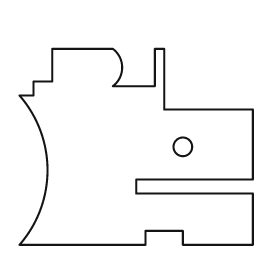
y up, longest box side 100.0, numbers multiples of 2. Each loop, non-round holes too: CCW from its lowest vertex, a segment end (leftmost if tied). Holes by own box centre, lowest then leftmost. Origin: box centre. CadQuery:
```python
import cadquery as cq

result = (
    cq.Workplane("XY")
    .moveTo(-50.0, -42.0)
    .lineTo(4.0, -42.0)
    .lineTo(4.0, -36.0)
    .lineTo(20.0, -36.0)
    .lineTo(20.0, -42.0)
    .lineTo(50.0, -42.0)
    .lineTo(50.0, -20.0)
    .lineTo(0.0, -20.0)
    .lineTo(0.0, -14.0)
    .lineTo(50.0, -14.0)
    .lineTo(50.0, 16.0)
    .lineTo(12.0, 16.0)
    .lineTo(12.0, 42.0)
    .lineTo(8.0, 42.0)
    .lineTo(8.0, 26.0)
    .lineTo(-10.0, 26.0)
    .threePointArc((-6.0, 34.0), (-10.0, 42.0))
    .lineTo(-36.0, 42.0)
    .lineTo(-36.0, 28.0)
    .lineTo(-44.0, 28.0)
    .lineTo(-44.0, 22.0)
    .lineTo(-50.0, 22.0)
    .threePointArc((-38.0, -10.0), (-50.0, -42.0))
    .close()
    .moveTo(20.0, 0.0)
    .circle(4.0)
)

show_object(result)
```